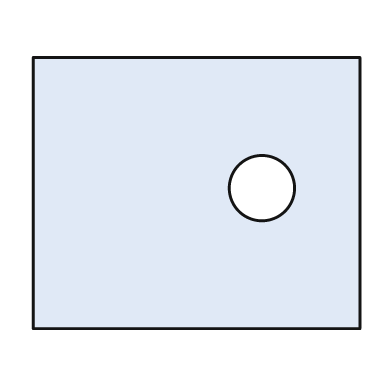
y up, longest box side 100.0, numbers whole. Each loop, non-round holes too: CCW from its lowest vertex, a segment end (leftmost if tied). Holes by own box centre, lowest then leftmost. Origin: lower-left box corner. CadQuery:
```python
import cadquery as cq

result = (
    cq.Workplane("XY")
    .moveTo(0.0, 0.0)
    .lineTo(100.0, 0.0)
    .lineTo(100.0, 83.0)
    .lineTo(0.0, 83.0)
    .close()
    .moveTo(70.0, 43.0)
    .circle(10.0)
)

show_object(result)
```